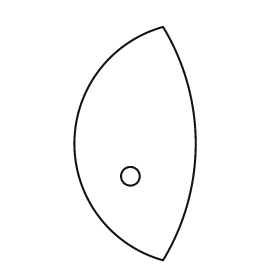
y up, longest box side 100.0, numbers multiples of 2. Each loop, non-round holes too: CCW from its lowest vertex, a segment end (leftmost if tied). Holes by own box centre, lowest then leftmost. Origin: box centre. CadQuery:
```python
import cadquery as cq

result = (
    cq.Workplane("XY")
    .moveTo(12.0, -50.0)
    .threePointArc((26.0, 0.0), (12.0, 50.0))
    .threePointArc((-26.0, 0.0), (12.0, -50.0))
    .close()
    .moveTo(-2.0, -14.0)
    .circle(4.0)
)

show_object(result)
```